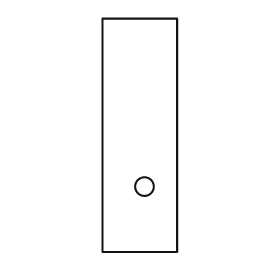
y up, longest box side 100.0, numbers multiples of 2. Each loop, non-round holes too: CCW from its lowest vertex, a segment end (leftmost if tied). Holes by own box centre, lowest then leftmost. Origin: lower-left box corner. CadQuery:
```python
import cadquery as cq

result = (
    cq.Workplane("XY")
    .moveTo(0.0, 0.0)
    .lineTo(32.0, 0.0)
    .lineTo(32.0, 100.0)
    .lineTo(0.0, 100.0)
    .close()
    .moveTo(18.0, 28.0)
    .circle(4.0)
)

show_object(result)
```